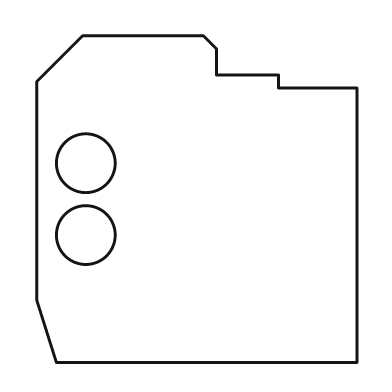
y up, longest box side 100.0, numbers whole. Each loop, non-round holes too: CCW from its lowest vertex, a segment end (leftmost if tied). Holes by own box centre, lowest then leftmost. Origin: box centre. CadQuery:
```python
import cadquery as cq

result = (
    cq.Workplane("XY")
    .moveTo(-43.0, -50.0)
    .lineTo(49.0, -50.0)
    .lineTo(49.0, 34.0)
    .lineTo(25.0, 34.0)
    .lineTo(25.0, 38.0)
    .lineTo(6.0, 38.0)
    .lineTo(6.0, 46.0)
    .lineTo(2.0, 50.0)
    .lineTo(-35.0, 50.0)
    .lineTo(-49.0, 36.0)
    .lineTo(-49.0, -31.0)
    .close()
    .moveTo(-34.0, -11.0)
    .circle(9.0)
    .moveTo(-34.0, 11.0)
    .circle(9.0)
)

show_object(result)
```